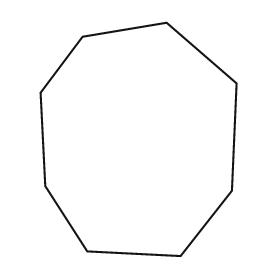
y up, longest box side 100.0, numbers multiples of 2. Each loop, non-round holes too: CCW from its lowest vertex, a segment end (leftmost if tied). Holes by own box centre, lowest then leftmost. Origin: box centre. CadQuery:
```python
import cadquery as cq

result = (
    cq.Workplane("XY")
    .moveTo(18.0, -50.0)
    .lineTo(40.0, -22.0)
    .lineTo(42.0, 24.0)
    .lineTo(12.0, 50.0)
    .lineTo(-24.0, 44.0)
    .lineTo(-42.0, 20.0)
    .lineTo(-40.0, -20.0)
    .lineTo(-22.0, -48.0)
    .close()
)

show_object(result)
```